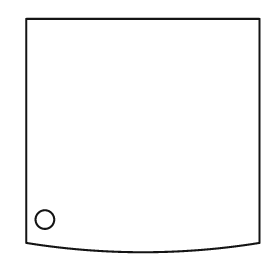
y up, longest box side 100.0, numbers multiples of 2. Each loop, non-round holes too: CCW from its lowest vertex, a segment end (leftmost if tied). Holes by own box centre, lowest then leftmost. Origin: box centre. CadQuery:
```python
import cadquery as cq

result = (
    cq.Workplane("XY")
    .moveTo(-50.0, -46.0)
    .threePointArc((0.0, -50.0), (50.0, -46.0))
    .lineTo(50.0, 50.0)
    .lineTo(-50.0, 50.0)
    .close()
    .moveTo(-42.0, -36.0)
    .circle(4.0)
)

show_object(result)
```